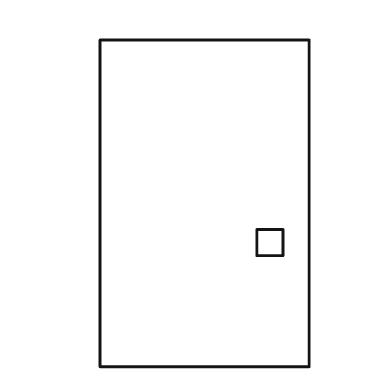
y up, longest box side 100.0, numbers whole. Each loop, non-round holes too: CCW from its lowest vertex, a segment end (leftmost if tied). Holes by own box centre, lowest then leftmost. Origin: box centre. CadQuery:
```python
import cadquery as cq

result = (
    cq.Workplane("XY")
    .moveTo(-32.0, -50.0)
    .lineTo(32.0, -50.0)
    .lineTo(32.0, 50.0)
    .lineTo(-32.0, 50.0)
    .close()
    .moveTo(16.0, -16.0)
    .lineTo(24.0, -16.0)
    .lineTo(24.0, -8.0)
    .lineTo(16.0, -8.0)
    .close()
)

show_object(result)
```